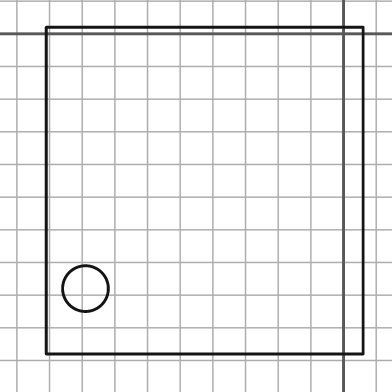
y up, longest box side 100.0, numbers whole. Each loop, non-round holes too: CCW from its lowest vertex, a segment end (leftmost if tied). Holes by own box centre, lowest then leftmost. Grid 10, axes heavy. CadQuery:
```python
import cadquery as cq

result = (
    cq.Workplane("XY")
    .moveTo(-91.0, -98.0)
    .lineTo(6.0, -98.0)
    .lineTo(6.0, 2.0)
    .lineTo(-91.0, 2.0)
    .close()
    .moveTo(-79.0, -78.0)
    .circle(7.0)
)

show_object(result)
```